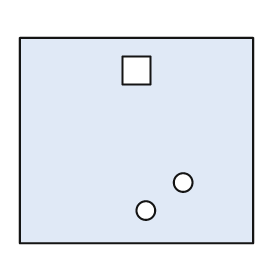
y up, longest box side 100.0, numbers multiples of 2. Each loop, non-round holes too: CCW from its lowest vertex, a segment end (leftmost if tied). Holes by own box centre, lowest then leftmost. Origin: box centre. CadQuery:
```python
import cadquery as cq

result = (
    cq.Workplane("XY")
    .moveTo(-50.0, -44.0)
    .lineTo(50.0, -44.0)
    .lineTo(50.0, 44.0)
    .lineTo(-50.0, 44.0)
    .close()
    .moveTo(4.0, -30.0)
    .circle(4.0)
    .moveTo(20.0, -18.0)
    .circle(4.0)
    .moveTo(-6.0, 24.0)
    .lineTo(6.0, 24.0)
    .lineTo(6.0, 36.0)
    .lineTo(-6.0, 36.0)
    .close()
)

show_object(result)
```